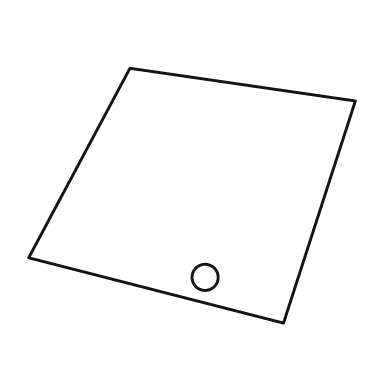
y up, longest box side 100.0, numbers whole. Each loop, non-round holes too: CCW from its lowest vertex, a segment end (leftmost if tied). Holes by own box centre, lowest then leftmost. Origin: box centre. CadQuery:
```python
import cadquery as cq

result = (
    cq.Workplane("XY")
    .moveTo(28.0, -39.0)
    .lineTo(50.0, 29.0)
    .lineTo(-19.0, 39.0)
    .lineTo(-50.0, -19.0)
    .close()
    .moveTo(4.0, -25.0)
    .circle(4.0)
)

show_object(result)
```